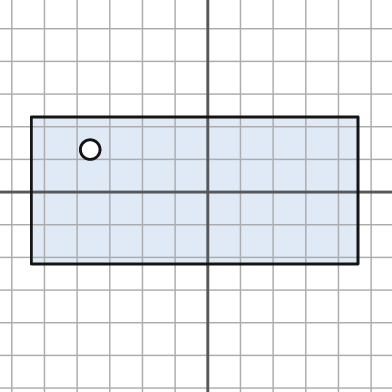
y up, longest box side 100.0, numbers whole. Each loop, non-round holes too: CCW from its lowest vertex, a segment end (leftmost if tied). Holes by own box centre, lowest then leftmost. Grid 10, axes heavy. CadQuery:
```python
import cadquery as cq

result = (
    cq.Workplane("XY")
    .moveTo(-54.0, -22.0)
    .lineTo(46.0, -22.0)
    .lineTo(46.0, 23.0)
    .lineTo(-54.0, 23.0)
    .close()
    .moveTo(-36.0, 13.0)
    .circle(3.0)
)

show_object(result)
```